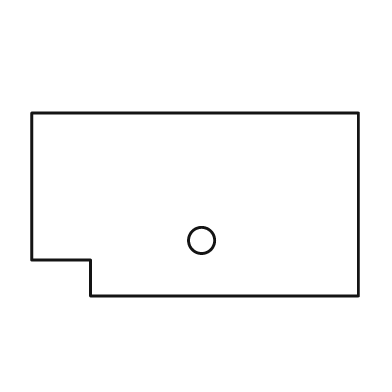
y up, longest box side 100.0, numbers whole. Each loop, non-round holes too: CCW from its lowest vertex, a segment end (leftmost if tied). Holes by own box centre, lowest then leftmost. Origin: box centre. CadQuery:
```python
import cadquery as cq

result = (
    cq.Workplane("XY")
    .moveTo(-32.0, -28.0)
    .lineTo(50.0, -28.0)
    .lineTo(50.0, 28.0)
    .lineTo(-50.0, 28.0)
    .lineTo(-50.0, -17.0)
    .lineTo(-32.0, -17.0)
    .close()
    .moveTo(2.0, -11.0)
    .circle(4.0)
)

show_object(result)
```